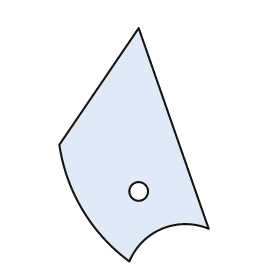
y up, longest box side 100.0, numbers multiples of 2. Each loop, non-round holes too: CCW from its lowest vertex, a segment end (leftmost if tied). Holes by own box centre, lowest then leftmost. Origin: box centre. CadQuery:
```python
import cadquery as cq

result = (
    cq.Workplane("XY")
    .moveTo(-2.0, -50.0)
    .threePointArc((12.0, -36.0), (32.0, -36.0))
    .lineTo(2.0, 50.0)
    .lineTo(-32.0, 0.0)
    .threePointArc((-22.0, -28.0), (-2.0, -50.0))
    .close()
    .moveTo(2.0, -20.0)
    .circle(4.0)
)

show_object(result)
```